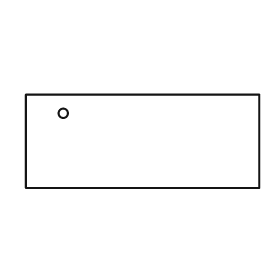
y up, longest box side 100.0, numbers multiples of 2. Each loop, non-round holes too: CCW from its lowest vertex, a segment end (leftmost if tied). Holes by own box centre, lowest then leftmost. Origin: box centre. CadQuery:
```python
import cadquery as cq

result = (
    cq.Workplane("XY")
    .moveTo(-50.0, -20.0)
    .lineTo(50.0, -20.0)
    .lineTo(50.0, 20.0)
    .lineTo(-50.0, 20.0)
    .close()
    .moveTo(-34.0, 12.0)
    .circle(2.0)
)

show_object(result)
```